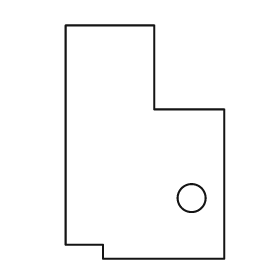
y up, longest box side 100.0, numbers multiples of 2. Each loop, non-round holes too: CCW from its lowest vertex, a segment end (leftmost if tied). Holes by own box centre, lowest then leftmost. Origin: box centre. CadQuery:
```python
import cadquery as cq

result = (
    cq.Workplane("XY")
    .moveTo(-18.0, -50.0)
    .lineTo(34.0, -50.0)
    .lineTo(34.0, 14.0)
    .lineTo(4.0, 14.0)
    .lineTo(4.0, 50.0)
    .lineTo(-34.0, 50.0)
    .lineTo(-34.0, -44.0)
    .lineTo(-18.0, -44.0)
    .close()
    .moveTo(20.0, -24.0)
    .circle(6.0)
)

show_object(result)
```